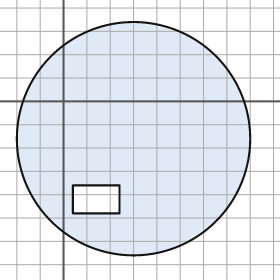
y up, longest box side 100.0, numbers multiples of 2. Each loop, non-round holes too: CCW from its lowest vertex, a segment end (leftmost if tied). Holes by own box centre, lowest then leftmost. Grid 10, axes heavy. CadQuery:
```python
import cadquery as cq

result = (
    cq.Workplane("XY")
    .moveTo(30.0, -16.0)
    .circle(50.0)
    .moveTo(4.0, -48.0)
    .lineTo(24.0, -48.0)
    .lineTo(24.0, -36.0)
    .lineTo(4.0, -36.0)
    .close()
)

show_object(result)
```